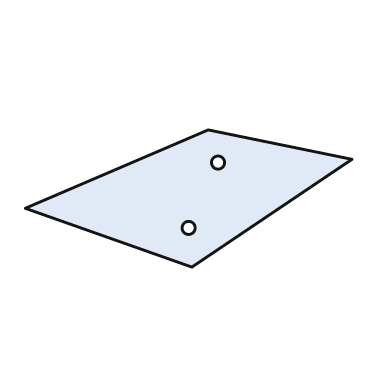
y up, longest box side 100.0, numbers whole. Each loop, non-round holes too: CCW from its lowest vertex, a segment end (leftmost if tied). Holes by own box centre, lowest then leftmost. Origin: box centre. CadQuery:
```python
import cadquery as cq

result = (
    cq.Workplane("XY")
    .moveTo(1.0, -21.0)
    .lineTo(50.0, 12.0)
    .lineTo(6.0, 21.0)
    .lineTo(-50.0, -3.0)
    .close()
    .moveTo(0.0, -9.0)
    .circle(2.0)
    .moveTo(9.0, 11.0)
    .circle(2.0)
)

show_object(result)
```